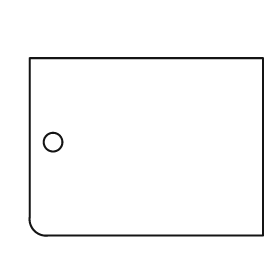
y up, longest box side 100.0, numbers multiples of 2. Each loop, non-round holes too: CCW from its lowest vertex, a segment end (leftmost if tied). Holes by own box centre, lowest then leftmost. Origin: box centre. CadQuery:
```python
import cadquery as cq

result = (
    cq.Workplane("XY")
    .moveTo(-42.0, -38.0)
    .lineTo(50.0, -38.0)
    .lineTo(50.0, 38.0)
    .lineTo(-50.0, 38.0)
    .lineTo(-50.0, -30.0)
    .threePointArc((-48.0, -36.0), (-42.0, -38.0))
    .close()
    .moveTo(-40.0, 2.0)
    .circle(4.0)
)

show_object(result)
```